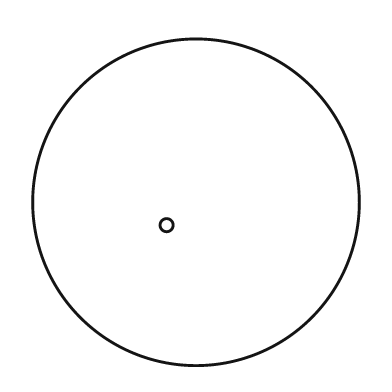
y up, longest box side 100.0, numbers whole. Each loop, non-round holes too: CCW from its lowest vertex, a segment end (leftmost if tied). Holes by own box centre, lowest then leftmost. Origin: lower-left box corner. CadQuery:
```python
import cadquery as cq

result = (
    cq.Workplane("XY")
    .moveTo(50.0, 50.0)
    .circle(50.0)
    .moveTo(41.0, 43.0)
    .circle(2.0)
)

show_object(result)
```